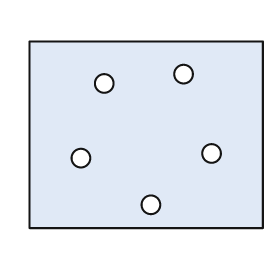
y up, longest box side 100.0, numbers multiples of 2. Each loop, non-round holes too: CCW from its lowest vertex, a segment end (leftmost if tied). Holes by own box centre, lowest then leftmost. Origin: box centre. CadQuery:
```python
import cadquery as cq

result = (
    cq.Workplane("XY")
    .moveTo(-50.0, -40.0)
    .lineTo(50.0, -40.0)
    .lineTo(50.0, 40.0)
    .lineTo(-50.0, 40.0)
    .close()
    .moveTo(2.0, -30.0)
    .circle(4.0)
    .moveTo(-28.0, -10.0)
    .circle(4.0)
    .moveTo(28.0, -8.0)
    .circle(4.0)
    .moveTo(-18.0, 22.0)
    .circle(4.0)
    .moveTo(16.0, 26.0)
    .circle(4.0)
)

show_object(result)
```